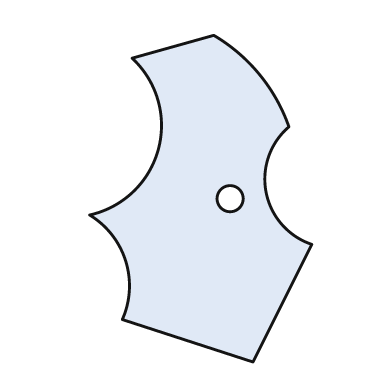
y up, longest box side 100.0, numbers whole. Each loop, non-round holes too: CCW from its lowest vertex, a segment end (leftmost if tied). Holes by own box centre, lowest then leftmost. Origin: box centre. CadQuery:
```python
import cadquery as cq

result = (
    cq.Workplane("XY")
    .moveTo(16.0, -50.0)
    .lineTo(34.0, -14.0)
    .threePointArc((20.0, 2.0), (27.0, 22.0))
    .threePointArc((18.0, 38.0), (4.0, 50.0))
    .lineTo(-21.0, 43.0)
    .threePointArc((-13.0, 15.0), (-34.0, -5.0))
    .threePointArc((-23.0, -19.0), (-24.0, -37.0))
    .close()
    .moveTo(9.0, 0.0)
    .circle(4.0)
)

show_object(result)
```